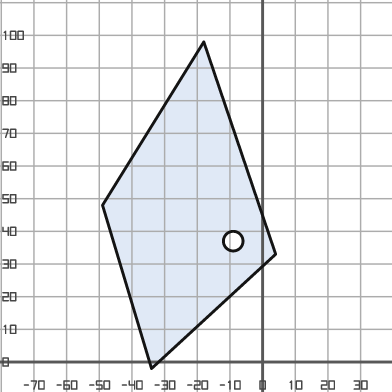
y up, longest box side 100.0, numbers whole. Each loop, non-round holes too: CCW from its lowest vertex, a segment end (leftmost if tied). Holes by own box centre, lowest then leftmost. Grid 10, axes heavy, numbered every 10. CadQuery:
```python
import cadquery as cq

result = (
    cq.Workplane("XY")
    .moveTo(-34.0, -2.0)
    .lineTo(4.0, 33.0)
    .lineTo(-18.0, 98.0)
    .lineTo(-49.0, 48.0)
    .close()
    .moveTo(-9.0, 37.0)
    .circle(3.0)
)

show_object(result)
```